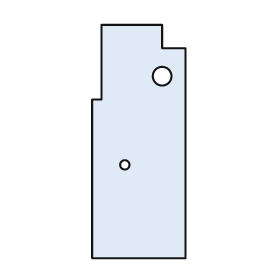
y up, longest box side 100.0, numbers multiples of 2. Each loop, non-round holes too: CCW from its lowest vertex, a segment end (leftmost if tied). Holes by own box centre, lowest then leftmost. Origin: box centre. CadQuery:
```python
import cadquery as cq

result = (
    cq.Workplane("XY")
    .moveTo(-20.0, -50.0)
    .lineTo(20.0, -50.0)
    .lineTo(20.0, 40.0)
    .lineTo(10.0, 40.0)
    .lineTo(10.0, 50.0)
    .lineTo(-16.0, 50.0)
    .lineTo(-16.0, 18.0)
    .lineTo(-20.0, 18.0)
    .close()
    .moveTo(-6.0, -10.0)
    .circle(2.0)
    .moveTo(10.0, 28.0)
    .circle(4.0)
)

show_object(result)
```